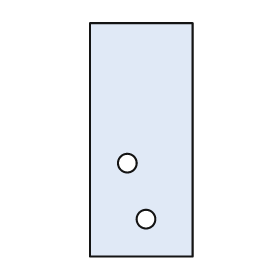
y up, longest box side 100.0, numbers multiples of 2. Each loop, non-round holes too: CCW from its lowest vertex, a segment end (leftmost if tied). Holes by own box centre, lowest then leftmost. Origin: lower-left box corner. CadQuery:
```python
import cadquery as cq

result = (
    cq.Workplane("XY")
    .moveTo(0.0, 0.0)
    .lineTo(44.0, 0.0)
    .lineTo(44.0, 100.0)
    .lineTo(0.0, 100.0)
    .close()
    .moveTo(24.0, 16.0)
    .circle(4.0)
    .moveTo(16.0, 40.0)
    .circle(4.0)
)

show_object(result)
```